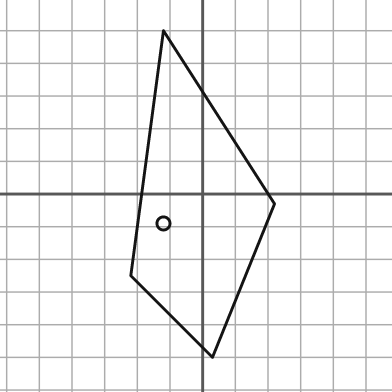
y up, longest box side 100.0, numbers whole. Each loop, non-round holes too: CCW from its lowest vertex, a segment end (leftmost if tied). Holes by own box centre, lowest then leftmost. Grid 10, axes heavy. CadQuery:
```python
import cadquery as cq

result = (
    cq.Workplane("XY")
    .moveTo(3.0, -50.0)
    .lineTo(22.0, -3.0)
    .lineTo(-12.0, 50.0)
    .lineTo(-22.0, -25.0)
    .close()
    .moveTo(-12.0, -9.0)
    .circle(2.0)
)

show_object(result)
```